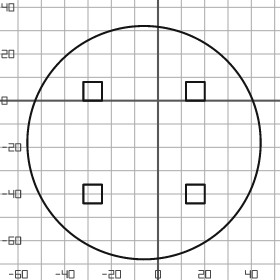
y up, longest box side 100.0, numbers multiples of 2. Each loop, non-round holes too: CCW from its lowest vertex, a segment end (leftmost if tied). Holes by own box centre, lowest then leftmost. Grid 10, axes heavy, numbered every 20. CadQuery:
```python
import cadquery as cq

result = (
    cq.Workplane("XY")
    .moveTo(-6.0, -18.0)
    .circle(50.0)
    .moveTo(-32.0, -44.0)
    .lineTo(-24.0, -44.0)
    .lineTo(-24.0, -36.0)
    .lineTo(-32.0, -36.0)
    .close()
    .moveTo(12.0, -44.0)
    .lineTo(20.0, -44.0)
    .lineTo(20.0, -36.0)
    .lineTo(12.0, -36.0)
    .close()
    .moveTo(-32.0, 0.0)
    .lineTo(-24.0, 0.0)
    .lineTo(-24.0, 8.0)
    .lineTo(-32.0, 8.0)
    .close()
    .moveTo(12.0, 0.0)
    .lineTo(20.0, 0.0)
    .lineTo(20.0, 8.0)
    .lineTo(12.0, 8.0)
    .close()
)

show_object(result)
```